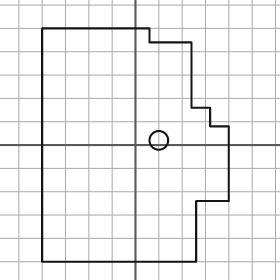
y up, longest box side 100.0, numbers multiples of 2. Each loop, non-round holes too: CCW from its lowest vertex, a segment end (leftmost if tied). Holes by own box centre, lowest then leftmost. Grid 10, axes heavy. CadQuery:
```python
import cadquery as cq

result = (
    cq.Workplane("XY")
    .moveTo(-40.0, -50.0)
    .lineTo(26.0, -50.0)
    .lineTo(26.0, -24.0)
    .lineTo(40.0, -24.0)
    .lineTo(40.0, 8.0)
    .lineTo(32.0, 8.0)
    .lineTo(32.0, 16.0)
    .lineTo(24.0, 16.0)
    .lineTo(24.0, 44.0)
    .lineTo(6.0, 44.0)
    .lineTo(6.0, 50.0)
    .lineTo(-40.0, 50.0)
    .close()
    .moveTo(10.0, 2.0)
    .circle(4.0)
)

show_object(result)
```